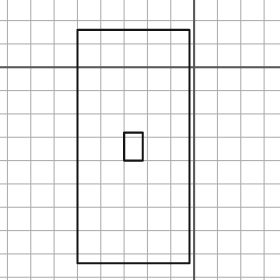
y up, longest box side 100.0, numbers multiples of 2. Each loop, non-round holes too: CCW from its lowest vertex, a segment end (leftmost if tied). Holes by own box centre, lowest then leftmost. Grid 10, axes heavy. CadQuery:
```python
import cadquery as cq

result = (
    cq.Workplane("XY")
    .moveTo(-50.0, -84.0)
    .lineTo(-2.0, -84.0)
    .lineTo(-2.0, 16.0)
    .lineTo(-50.0, 16.0)
    .close()
    .moveTo(-30.0, -40.0)
    .lineTo(-22.0, -40.0)
    .lineTo(-22.0, -28.0)
    .lineTo(-30.0, -28.0)
    .close()
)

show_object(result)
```